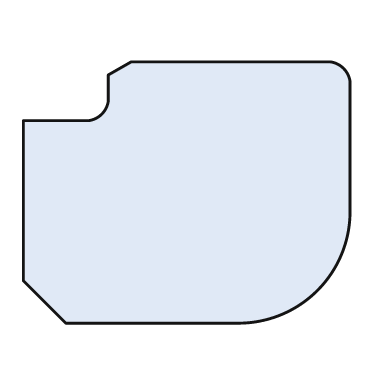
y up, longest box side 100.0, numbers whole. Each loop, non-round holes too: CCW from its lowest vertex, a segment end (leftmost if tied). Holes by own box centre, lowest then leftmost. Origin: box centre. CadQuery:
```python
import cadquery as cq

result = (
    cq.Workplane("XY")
    .moveTo(-37.0, -40.0)
    .lineTo(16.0, -40.0)
    .threePointArc((40.0, -30.0), (50.0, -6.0))
    .lineTo(50.0, 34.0)
    .threePointArc((48.0, 38.0), (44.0, 40.0))
    .lineTo(-17.0, 40.0)
    .lineTo(-24.0, 36.0)
    .lineTo(-24.0, 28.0)
    .threePointArc((-26.0, 24.0), (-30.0, 22.0))
    .lineTo(-50.0, 22.0)
    .lineTo(-50.0, -27.0)
    .close()
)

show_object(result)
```